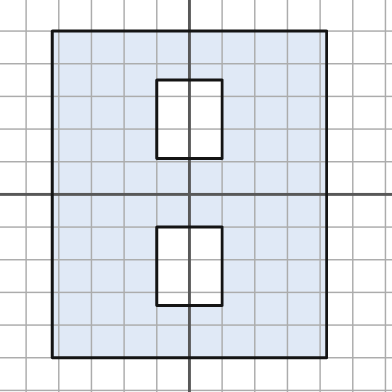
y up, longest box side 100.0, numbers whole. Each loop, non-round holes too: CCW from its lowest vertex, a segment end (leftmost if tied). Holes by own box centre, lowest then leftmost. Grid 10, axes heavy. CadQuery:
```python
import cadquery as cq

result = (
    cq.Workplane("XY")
    .moveTo(-42.0, -50.0)
    .lineTo(42.0, -50.0)
    .lineTo(42.0, 50.0)
    .lineTo(-42.0, 50.0)
    .close()
    .moveTo(-10.0, -34.0)
    .lineTo(10.0, -34.0)
    .lineTo(10.0, -10.0)
    .lineTo(-10.0, -10.0)
    .close()
    .moveTo(-10.0, 11.0)
    .lineTo(10.0, 11.0)
    .lineTo(10.0, 35.0)
    .lineTo(-10.0, 35.0)
    .close()
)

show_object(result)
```